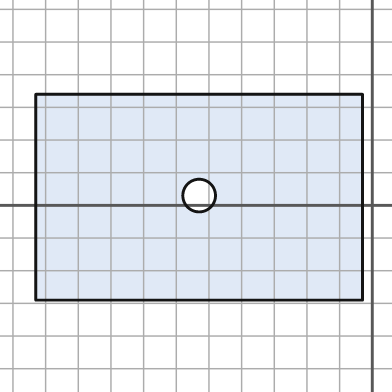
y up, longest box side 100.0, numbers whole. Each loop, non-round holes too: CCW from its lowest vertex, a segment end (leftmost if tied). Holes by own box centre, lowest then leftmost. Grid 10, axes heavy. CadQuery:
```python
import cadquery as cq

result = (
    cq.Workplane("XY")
    .moveTo(-103.0, -29.0)
    .lineTo(-3.0, -29.0)
    .lineTo(-3.0, 34.0)
    .lineTo(-103.0, 34.0)
    .close()
    .moveTo(-53.0, 3.0)
    .circle(5.0)
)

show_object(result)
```